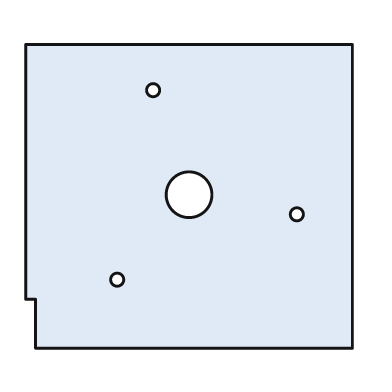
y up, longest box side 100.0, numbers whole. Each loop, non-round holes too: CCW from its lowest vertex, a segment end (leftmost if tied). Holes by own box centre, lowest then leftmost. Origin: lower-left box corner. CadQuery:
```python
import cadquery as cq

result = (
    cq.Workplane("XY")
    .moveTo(3.0, 0.0)
    .lineTo(100.0, 0.0)
    .lineTo(100.0, 93.0)
    .lineTo(0.0, 93.0)
    .lineTo(0.0, 15.0)
    .lineTo(3.0, 15.0)
    .close()
    .moveTo(28.0, 21.0)
    .circle(2.0)
    .moveTo(83.0, 41.0)
    .circle(2.0)
    .moveTo(50.0, 47.0)
    .circle(7.0)
    .moveTo(39.0, 79.0)
    .circle(2.0)
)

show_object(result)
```